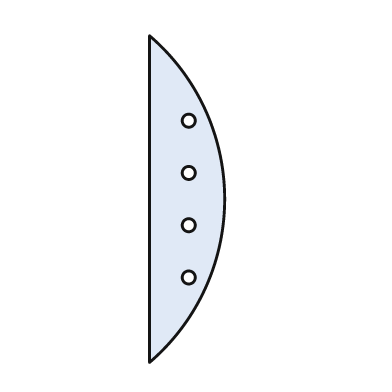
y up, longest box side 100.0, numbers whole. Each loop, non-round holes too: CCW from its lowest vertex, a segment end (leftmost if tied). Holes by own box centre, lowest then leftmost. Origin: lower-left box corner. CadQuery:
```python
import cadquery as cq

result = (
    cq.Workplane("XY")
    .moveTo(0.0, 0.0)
    .threePointArc((23.0, 50.0), (0.0, 100.0))
    .close()
    .moveTo(12.0, 26.0)
    .circle(2.0)
    .moveTo(12.0, 42.0)
    .circle(2.0)
    .moveTo(12.0, 58.0)
    .circle(2.0)
    .moveTo(12.0, 74.0)
    .circle(2.0)
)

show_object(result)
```